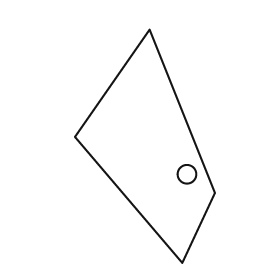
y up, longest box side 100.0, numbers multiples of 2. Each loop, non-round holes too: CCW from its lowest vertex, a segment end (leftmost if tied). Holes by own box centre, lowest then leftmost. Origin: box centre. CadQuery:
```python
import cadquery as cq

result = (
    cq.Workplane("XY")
    .moveTo(16.0, -50.0)
    .lineTo(30.0, -20.0)
    .lineTo(2.0, 50.0)
    .lineTo(-30.0, 4.0)
    .close()
    .moveTo(18.0, -12.0)
    .circle(4.0)
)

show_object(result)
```